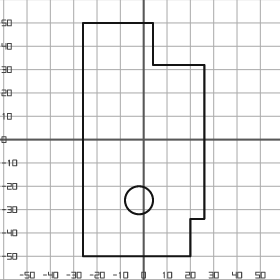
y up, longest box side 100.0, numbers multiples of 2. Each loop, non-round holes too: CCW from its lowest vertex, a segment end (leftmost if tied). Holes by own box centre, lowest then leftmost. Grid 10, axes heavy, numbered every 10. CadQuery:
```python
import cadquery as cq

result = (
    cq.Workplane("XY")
    .moveTo(-26.0, -50.0)
    .lineTo(20.0, -50.0)
    .lineTo(20.0, -34.0)
    .lineTo(26.0, -34.0)
    .lineTo(26.0, 32.0)
    .lineTo(4.0, 32.0)
    .lineTo(4.0, 50.0)
    .lineTo(-26.0, 50.0)
    .close()
    .moveTo(-2.0, -26.0)
    .circle(6.0)
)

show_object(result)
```